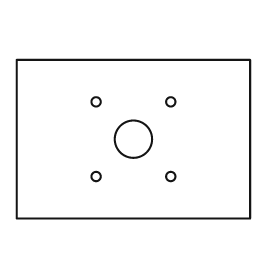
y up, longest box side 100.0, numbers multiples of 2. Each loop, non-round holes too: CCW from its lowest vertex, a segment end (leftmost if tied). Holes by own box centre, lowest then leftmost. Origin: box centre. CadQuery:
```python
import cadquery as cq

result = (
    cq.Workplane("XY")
    .moveTo(-50.0, -34.0)
    .lineTo(50.0, -34.0)
    .lineTo(50.0, 34.0)
    .lineTo(-50.0, 34.0)
    .close()
    .moveTo(-16.0, -16.0)
    .circle(2.0)
    .moveTo(16.0, -16.0)
    .circle(2.0)
    .moveTo(0.0, 0.0)
    .circle(8.0)
    .moveTo(-16.0, 16.0)
    .circle(2.0)
    .moveTo(16.0, 16.0)
    .circle(2.0)
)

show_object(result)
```